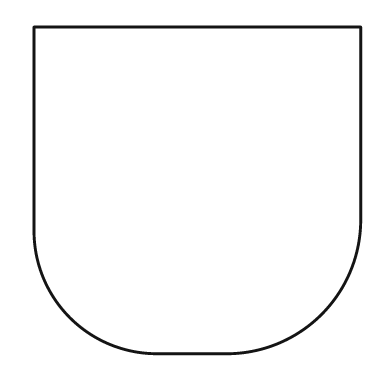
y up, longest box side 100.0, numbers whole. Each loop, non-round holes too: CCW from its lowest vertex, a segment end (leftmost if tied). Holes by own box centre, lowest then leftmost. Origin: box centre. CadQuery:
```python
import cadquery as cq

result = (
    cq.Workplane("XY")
    .moveTo(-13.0, -50.0)
    .lineTo(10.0, -50.0)
    .threePointArc((38.0, -38.0), (50.0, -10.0))
    .lineTo(50.0, 50.0)
    .lineTo(-50.0, 50.0)
    .lineTo(-50.0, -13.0)
    .threePointArc((-39.0, -39.0), (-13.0, -50.0))
    .close()
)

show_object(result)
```